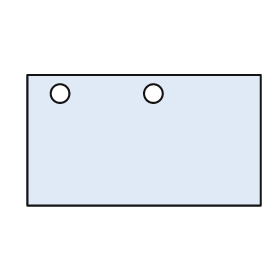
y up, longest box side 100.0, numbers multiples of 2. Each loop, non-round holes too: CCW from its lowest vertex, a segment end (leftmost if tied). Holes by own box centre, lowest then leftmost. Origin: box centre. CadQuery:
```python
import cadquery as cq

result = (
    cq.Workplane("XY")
    .moveTo(-50.0, -28.0)
    .lineTo(50.0, -28.0)
    .lineTo(50.0, 28.0)
    .lineTo(-50.0, 28.0)
    .close()
    .moveTo(-36.0, 20.0)
    .circle(4.0)
    .moveTo(4.0, 20.0)
    .circle(4.0)
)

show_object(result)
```